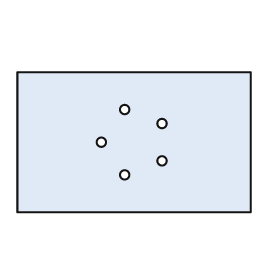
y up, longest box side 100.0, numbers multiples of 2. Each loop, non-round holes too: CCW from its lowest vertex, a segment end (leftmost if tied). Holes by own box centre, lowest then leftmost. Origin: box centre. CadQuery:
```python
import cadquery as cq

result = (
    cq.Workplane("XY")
    .moveTo(-50.0, -30.0)
    .lineTo(50.0, -30.0)
    .lineTo(50.0, 30.0)
    .lineTo(-50.0, 30.0)
    .close()
    .moveTo(-4.0, -14.0)
    .circle(2.0)
    .moveTo(12.0, -8.0)
    .circle(2.0)
    .moveTo(-14.0, 0.0)
    .circle(2.0)
    .moveTo(12.0, 8.0)
    .circle(2.0)
    .moveTo(-4.0, 14.0)
    .circle(2.0)
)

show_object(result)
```